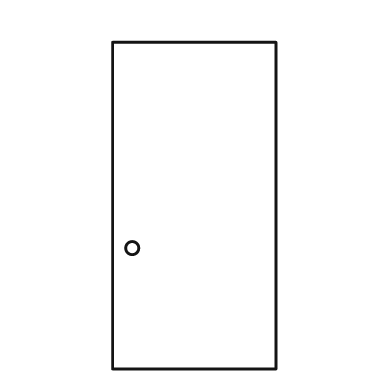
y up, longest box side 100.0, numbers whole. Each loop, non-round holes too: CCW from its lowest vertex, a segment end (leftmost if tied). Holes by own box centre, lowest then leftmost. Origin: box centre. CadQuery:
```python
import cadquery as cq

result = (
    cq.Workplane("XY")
    .moveTo(-25.0, -50.0)
    .lineTo(25.0, -50.0)
    .lineTo(25.0, 50.0)
    .lineTo(-25.0, 50.0)
    .close()
    .moveTo(-19.0, -13.0)
    .circle(2.0)
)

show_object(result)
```